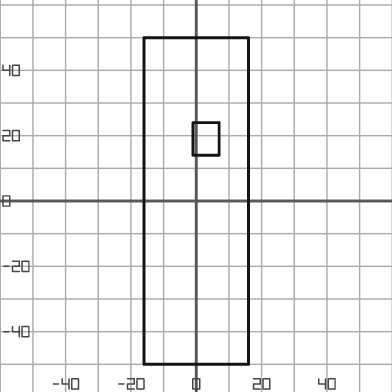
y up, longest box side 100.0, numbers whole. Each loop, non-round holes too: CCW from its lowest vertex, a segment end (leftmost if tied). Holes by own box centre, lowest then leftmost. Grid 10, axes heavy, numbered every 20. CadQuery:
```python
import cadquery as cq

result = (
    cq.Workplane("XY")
    .moveTo(-16.0, -50.0)
    .lineTo(16.0, -50.0)
    .lineTo(16.0, 50.0)
    .lineTo(-16.0, 50.0)
    .close()
    .moveTo(-1.0, 14.0)
    .lineTo(7.0, 14.0)
    .lineTo(7.0, 24.0)
    .lineTo(-1.0, 24.0)
    .close()
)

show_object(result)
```